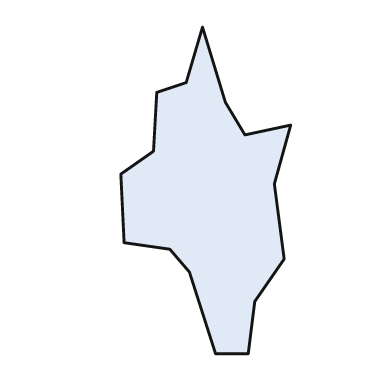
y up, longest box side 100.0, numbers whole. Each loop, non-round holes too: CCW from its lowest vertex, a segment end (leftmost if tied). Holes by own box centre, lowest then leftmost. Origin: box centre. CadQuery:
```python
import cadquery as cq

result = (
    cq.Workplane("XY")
    .moveTo(3.0, -50.0)
    .lineTo(13.0, -50.0)
    .lineTo(15.0, -34.0)
    .lineTo(24.0, -21.0)
    .lineTo(21.0, 2.0)
    .lineTo(26.0, 20.0)
    .lineTo(12.0, 17.0)
    .lineTo(6.0, 27.0)
    .lineTo(-1.0, 50.0)
    .lineTo(-6.0, 33.0)
    .lineTo(-15.0, 30.0)
    .lineTo(-16.0, 12.0)
    .lineTo(-26.0, 5.0)
    .lineTo(-25.0, -16.0)
    .lineTo(-11.0, -18.0)
    .lineTo(-5.0, -25.0)
    .close()
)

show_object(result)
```